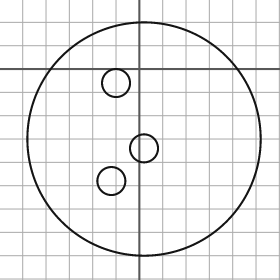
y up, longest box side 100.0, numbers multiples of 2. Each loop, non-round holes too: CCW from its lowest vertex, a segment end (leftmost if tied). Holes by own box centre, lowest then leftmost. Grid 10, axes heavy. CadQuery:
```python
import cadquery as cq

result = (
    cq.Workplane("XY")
    .moveTo(2.0, -30.0)
    .circle(50.0)
    .moveTo(-12.0, -48.0)
    .circle(6.0)
    .moveTo(2.0, -34.0)
    .circle(6.0)
    .moveTo(-10.0, -6.0)
    .circle(6.0)
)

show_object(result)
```